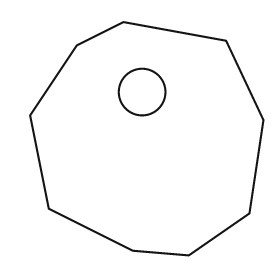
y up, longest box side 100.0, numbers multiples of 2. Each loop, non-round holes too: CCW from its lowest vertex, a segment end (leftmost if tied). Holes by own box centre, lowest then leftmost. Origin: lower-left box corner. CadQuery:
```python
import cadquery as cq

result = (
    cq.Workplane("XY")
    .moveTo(68.0, 0.0)
    .lineTo(94.0, 18.0)
    .lineTo(100.0, 58.0)
    .lineTo(84.0, 92.0)
    .lineTo(40.0, 100.0)
    .lineTo(20.0, 90.0)
    .lineTo(0.0, 60.0)
    .lineTo(8.0, 20.0)
    .lineTo(44.0, 2.0)
    .close()
    .moveTo(48.0, 70.0)
    .circle(10.0)
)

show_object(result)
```